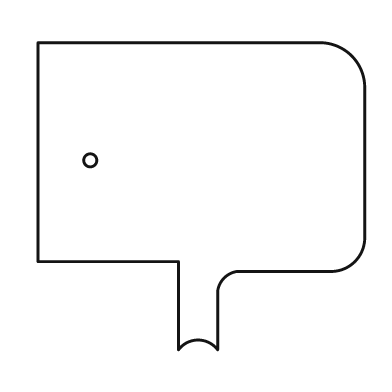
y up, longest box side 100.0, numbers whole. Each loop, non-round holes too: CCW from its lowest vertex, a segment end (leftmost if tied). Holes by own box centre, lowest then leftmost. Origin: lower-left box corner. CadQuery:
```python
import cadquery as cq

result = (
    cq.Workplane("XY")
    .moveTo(43.0, 0.0)
    .threePointArc((49.0, 3.0), (55.0, 0.0))
    .lineTo(55.0, 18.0)
    .threePointArc((57.0, 22.0), (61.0, 24.0))
    .lineTo(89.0, 24.0)
    .threePointArc((97.0, 27.0), (100.0, 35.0))
    .lineTo(100.0, 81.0)
    .threePointArc((96.0, 90.0), (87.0, 94.0))
    .lineTo(0.0, 94.0)
    .lineTo(0.0, 27.0)
    .lineTo(43.0, 27.0)
    .close()
    .moveTo(16.0, 58.0)
    .circle(2.0)
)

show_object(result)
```